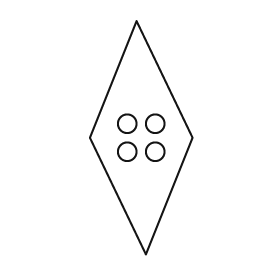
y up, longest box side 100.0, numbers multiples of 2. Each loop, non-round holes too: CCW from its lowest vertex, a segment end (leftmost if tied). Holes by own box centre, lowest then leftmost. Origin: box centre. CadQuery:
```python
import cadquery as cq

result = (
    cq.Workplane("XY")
    .moveTo(2.0, -50.0)
    .lineTo(22.0, 0.0)
    .lineTo(-2.0, 50.0)
    .lineTo(-22.0, 0.0)
    .close()
    .moveTo(-6.0, -6.0)
    .circle(4.0)
    .moveTo(6.0, -6.0)
    .circle(4.0)
    .moveTo(-6.0, 6.0)
    .circle(4.0)
    .moveTo(6.0, 6.0)
    .circle(4.0)
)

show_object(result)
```